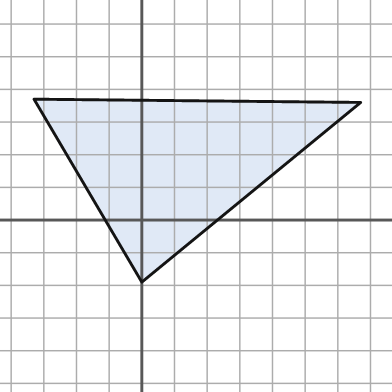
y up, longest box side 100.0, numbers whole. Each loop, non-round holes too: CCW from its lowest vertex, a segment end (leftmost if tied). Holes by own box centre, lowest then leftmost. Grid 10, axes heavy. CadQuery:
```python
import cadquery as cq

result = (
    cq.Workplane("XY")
    .moveTo(0.0, -19.0)
    .lineTo(67.0, 36.0)
    .lineTo(-33.0, 37.0)
    .close()
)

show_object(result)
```